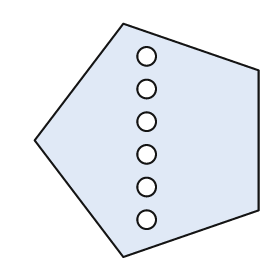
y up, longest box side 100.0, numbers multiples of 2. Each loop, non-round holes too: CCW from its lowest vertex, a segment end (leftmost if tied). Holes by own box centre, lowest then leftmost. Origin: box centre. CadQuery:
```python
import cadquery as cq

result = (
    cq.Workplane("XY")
    .moveTo(-10.0, -50.0)
    .lineTo(48.0, -30.0)
    .lineTo(48.0, 30.0)
    .lineTo(-10.0, 50.0)
    .lineTo(-48.0, 0.0)
    .close()
    .moveTo(0.0, -34.0)
    .circle(4.0)
    .moveTo(0.0, -20.0)
    .circle(4.0)
    .moveTo(0.0, -6.0)
    .circle(4.0)
    .moveTo(0.0, 8.0)
    .circle(4.0)
    .moveTo(0.0, 22.0)
    .circle(4.0)
    .moveTo(0.0, 36.0)
    .circle(4.0)
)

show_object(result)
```